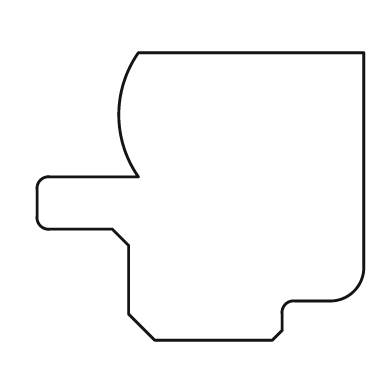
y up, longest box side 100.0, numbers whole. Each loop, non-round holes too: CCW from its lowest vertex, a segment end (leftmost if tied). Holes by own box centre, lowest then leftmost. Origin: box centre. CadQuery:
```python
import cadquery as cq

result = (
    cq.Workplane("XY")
    .moveTo(-14.0, -44.0)
    .lineTo(22.0, -44.0)
    .lineTo(25.0, -41.0)
    .lineTo(25.0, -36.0)
    .threePointArc((26.0, -33.0), (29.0, -32.0))
    .lineTo(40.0, -32.0)
    .threePointArc((47.0, -29.0), (50.0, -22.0))
    .lineTo(50.0, 44.0)
    .lineTo(-19.0, 44.0)
    .threePointArc((-25.0, 25.0), (-19.0, 6.0))
    .lineTo(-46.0, 6.0)
    .threePointArc((-49.0, 5.0), (-50.0, 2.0))
    .lineTo(-50.0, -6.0)
    .threePointArc((-49.0, -9.0), (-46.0, -10.0))
    .lineTo(-27.0, -10.0)
    .lineTo(-22.0, -15.0)
    .lineTo(-22.0, -36.0)
    .close()
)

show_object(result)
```